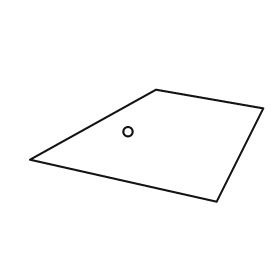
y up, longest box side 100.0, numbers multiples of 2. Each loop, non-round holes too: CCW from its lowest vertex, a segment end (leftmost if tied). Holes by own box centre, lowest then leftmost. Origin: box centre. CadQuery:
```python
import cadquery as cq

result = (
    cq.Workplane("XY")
    .moveTo(30.0, -24.0)
    .lineTo(50.0, 16.0)
    .lineTo(4.0, 24.0)
    .lineTo(-50.0, -6.0)
    .close()
    .moveTo(-8.0, 6.0)
    .circle(2.0)
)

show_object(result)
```